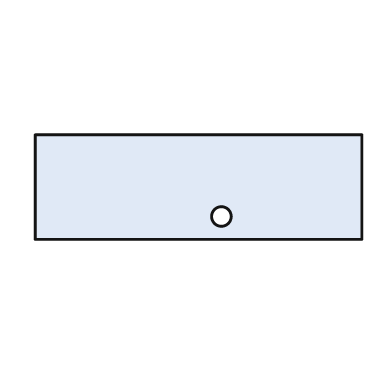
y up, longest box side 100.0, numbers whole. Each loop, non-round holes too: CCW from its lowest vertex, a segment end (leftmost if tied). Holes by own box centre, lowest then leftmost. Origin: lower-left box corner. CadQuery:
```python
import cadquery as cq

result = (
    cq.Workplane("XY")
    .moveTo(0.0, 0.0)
    .lineTo(100.0, 0.0)
    .lineTo(100.0, 32.0)
    .lineTo(0.0, 32.0)
    .close()
    .moveTo(57.0, 7.0)
    .circle(3.0)
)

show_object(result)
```